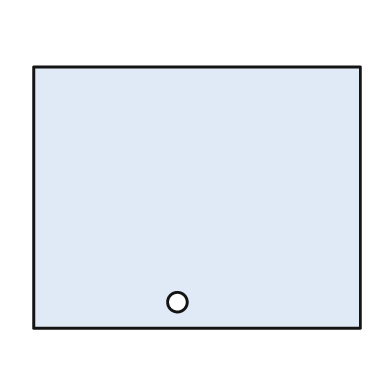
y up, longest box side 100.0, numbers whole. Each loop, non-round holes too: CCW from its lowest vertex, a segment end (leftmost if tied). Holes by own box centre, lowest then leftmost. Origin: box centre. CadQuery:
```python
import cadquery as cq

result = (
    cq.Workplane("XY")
    .moveTo(-50.0, -40.0)
    .lineTo(50.0, -40.0)
    .lineTo(50.0, 40.0)
    .lineTo(-50.0, 40.0)
    .close()
    .moveTo(-6.0, -32.0)
    .circle(3.0)
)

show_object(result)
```